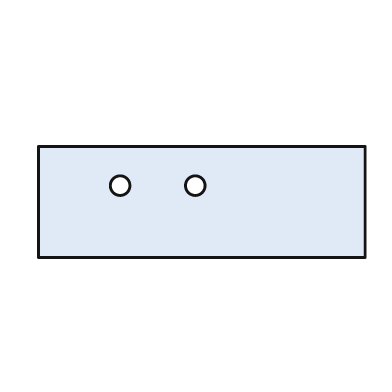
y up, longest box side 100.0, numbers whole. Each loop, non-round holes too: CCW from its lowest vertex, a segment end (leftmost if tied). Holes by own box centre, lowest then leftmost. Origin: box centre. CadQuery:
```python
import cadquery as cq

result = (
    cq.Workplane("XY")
    .moveTo(-50.0, -17.0)
    .lineTo(50.0, -17.0)
    .lineTo(50.0, 17.0)
    .lineTo(-50.0, 17.0)
    .close()
    .moveTo(-25.0, 5.0)
    .circle(3.0)
    .moveTo(-2.0, 5.0)
    .circle(3.0)
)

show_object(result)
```